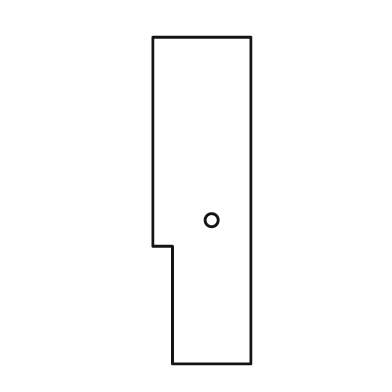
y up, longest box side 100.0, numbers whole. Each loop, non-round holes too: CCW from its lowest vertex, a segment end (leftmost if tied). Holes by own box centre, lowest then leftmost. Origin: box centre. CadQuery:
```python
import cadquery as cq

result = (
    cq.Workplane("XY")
    .moveTo(-9.0, -50.0)
    .lineTo(15.0, -50.0)
    .lineTo(15.0, 50.0)
    .lineTo(-15.0, 50.0)
    .lineTo(-15.0, -14.0)
    .lineTo(-9.0, -14.0)
    .close()
    .moveTo(3.0, -6.0)
    .circle(2.0)
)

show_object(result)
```